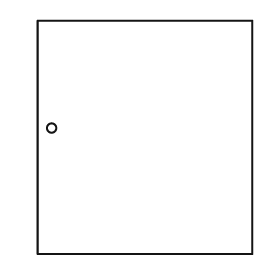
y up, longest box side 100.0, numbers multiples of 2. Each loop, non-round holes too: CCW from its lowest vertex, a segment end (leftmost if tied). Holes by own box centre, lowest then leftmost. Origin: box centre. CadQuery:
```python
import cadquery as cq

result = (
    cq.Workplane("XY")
    .moveTo(-46.0, -50.0)
    .lineTo(46.0, -50.0)
    .lineTo(46.0, 50.0)
    .lineTo(-46.0, 50.0)
    .close()
    .moveTo(-40.0, 4.0)
    .circle(2.0)
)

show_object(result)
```